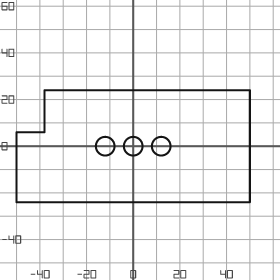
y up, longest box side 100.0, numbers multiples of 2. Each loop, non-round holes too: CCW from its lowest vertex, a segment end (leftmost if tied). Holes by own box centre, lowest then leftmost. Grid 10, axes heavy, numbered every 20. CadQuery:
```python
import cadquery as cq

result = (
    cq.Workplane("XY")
    .moveTo(-50.0, -24.0)
    .lineTo(50.0, -24.0)
    .lineTo(50.0, 24.0)
    .lineTo(-38.0, 24.0)
    .lineTo(-38.0, 6.0)
    .lineTo(-50.0, 6.0)
    .close()
    .moveTo(-12.0, 0.0)
    .circle(4.0)
    .moveTo(0.0, 0.0)
    .circle(4.0)
    .moveTo(12.0, 0.0)
    .circle(4.0)
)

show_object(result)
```